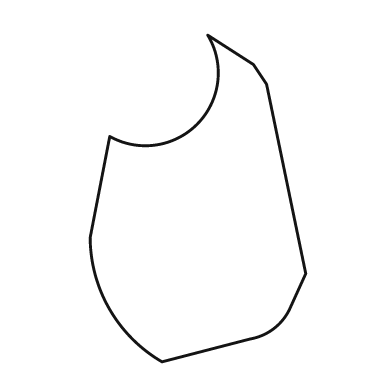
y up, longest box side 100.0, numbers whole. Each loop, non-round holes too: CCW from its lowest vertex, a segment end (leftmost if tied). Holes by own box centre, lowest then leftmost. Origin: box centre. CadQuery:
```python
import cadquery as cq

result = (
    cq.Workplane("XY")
    .moveTo(-11.0, -50.0)
    .lineTo(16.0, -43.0)
    .threePointArc((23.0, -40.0), (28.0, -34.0))
    .lineTo(33.0, -23.0)
    .lineTo(21.0, 35.0)
    .lineTo(17.0, 41.0)
    .lineTo(3.0, 50.0)
    .threePointArc((0.0, 23.0), (-27.0, 19.0))
    .lineTo(-33.0, -12.0)
    .threePointArc((-27.0, -34.0), (-11.0, -50.0))
    .close()
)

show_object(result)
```